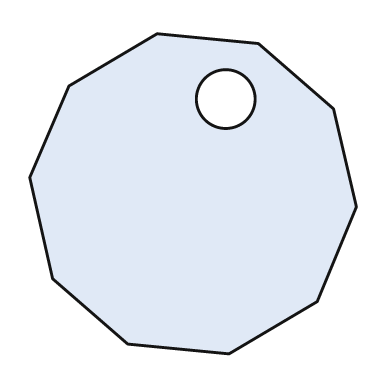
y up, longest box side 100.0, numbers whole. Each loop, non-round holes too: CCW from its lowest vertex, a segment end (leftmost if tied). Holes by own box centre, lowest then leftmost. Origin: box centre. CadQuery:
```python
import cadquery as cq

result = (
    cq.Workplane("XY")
    .moveTo(11.0, -49.0)
    .lineTo(38.0, -33.0)
    .lineTo(50.0, -4.0)
    .lineTo(43.0, 26.0)
    .lineTo(20.0, 46.0)
    .lineTo(-11.0, 49.0)
    .lineTo(-38.0, 33.0)
    .lineTo(-50.0, 5.0)
    .lineTo(-43.0, -26.0)
    .lineTo(-20.0, -46.0)
    .close()
    .moveTo(10.0, 29.0)
    .circle(9.0)
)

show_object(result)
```